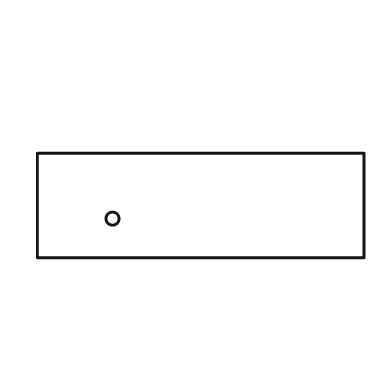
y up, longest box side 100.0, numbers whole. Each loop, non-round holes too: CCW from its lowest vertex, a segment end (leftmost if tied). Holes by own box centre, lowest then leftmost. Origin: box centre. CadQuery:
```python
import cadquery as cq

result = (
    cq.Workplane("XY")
    .moveTo(-50.0, -16.0)
    .lineTo(50.0, -16.0)
    .lineTo(50.0, 16.0)
    .lineTo(-50.0, 16.0)
    .close()
    .moveTo(-27.0, -4.0)
    .circle(2.0)
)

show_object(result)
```